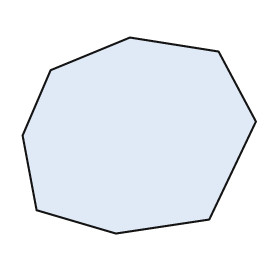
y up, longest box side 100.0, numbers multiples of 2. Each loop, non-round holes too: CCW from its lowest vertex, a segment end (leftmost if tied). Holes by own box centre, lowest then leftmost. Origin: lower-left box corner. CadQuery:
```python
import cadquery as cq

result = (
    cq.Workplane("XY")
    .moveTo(40.0, 0.0)
    .lineTo(80.0, 6.0)
    .lineTo(100.0, 48.0)
    .lineTo(84.0, 78.0)
    .lineTo(46.0, 84.0)
    .lineTo(12.0, 70.0)
    .lineTo(0.0, 42.0)
    .lineTo(6.0, 10.0)
    .close()
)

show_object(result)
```